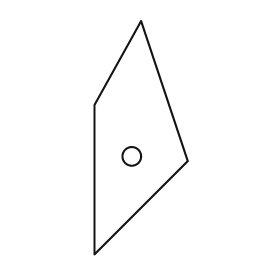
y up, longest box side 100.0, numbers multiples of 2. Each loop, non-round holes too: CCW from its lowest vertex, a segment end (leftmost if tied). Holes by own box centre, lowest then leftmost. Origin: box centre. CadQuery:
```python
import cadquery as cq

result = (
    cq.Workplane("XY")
    .moveTo(-20.0, -50.0)
    .lineTo(20.0, -10.0)
    .lineTo(0.0, 50.0)
    .lineTo(-20.0, 14.0)
    .close()
    .moveTo(-4.0, -8.0)
    .circle(4.0)
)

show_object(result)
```